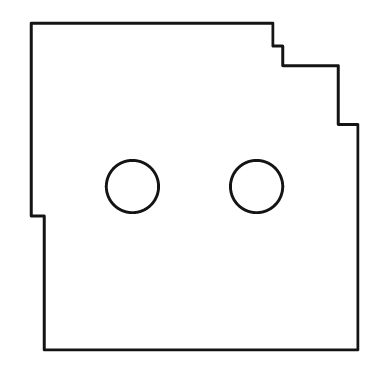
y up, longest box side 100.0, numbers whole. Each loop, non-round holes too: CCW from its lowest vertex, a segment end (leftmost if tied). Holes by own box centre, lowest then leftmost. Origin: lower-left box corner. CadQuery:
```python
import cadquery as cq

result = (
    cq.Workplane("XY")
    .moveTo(4.0, 0.0)
    .lineTo(100.0, 0.0)
    .lineTo(100.0, 69.0)
    .lineTo(94.0, 69.0)
    .lineTo(94.0, 87.0)
    .lineTo(77.0, 87.0)
    .lineTo(77.0, 93.0)
    .lineTo(74.0, 93.0)
    .lineTo(74.0, 100.0)
    .lineTo(0.0, 100.0)
    .lineTo(0.0, 41.0)
    .lineTo(4.0, 41.0)
    .close()
    .moveTo(31.0, 50.0)
    .circle(8.0)
    .moveTo(69.0, 50.0)
    .circle(8.0)
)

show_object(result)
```